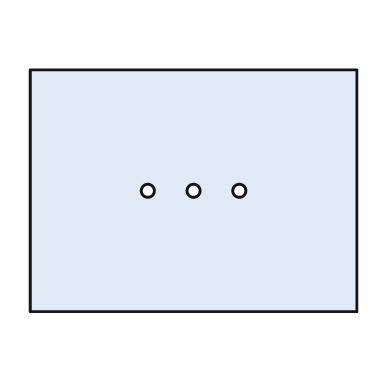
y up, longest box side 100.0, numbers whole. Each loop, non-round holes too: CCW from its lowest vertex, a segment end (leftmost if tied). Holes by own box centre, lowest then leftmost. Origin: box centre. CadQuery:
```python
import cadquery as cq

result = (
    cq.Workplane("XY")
    .moveTo(-50.0, -37.0)
    .lineTo(50.0, -37.0)
    .lineTo(50.0, 37.0)
    .lineTo(-50.0, 37.0)
    .close()
    .moveTo(-14.0, 0.0)
    .circle(2.0)
    .moveTo(0.0, 0.0)
    .circle(2.0)
    .moveTo(14.0, 0.0)
    .circle(2.0)
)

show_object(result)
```